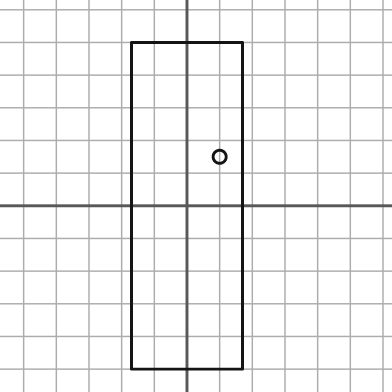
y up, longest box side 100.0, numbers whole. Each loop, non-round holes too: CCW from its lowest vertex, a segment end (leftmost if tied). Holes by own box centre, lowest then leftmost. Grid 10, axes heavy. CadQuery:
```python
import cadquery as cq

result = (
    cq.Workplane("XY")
    .moveTo(-17.0, -50.0)
    .lineTo(17.0, -50.0)
    .lineTo(17.0, 50.0)
    .lineTo(-17.0, 50.0)
    .close()
    .moveTo(10.0, 15.0)
    .circle(2.0)
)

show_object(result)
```